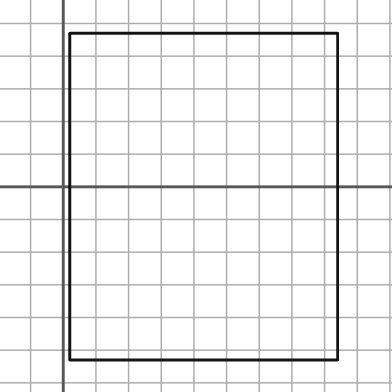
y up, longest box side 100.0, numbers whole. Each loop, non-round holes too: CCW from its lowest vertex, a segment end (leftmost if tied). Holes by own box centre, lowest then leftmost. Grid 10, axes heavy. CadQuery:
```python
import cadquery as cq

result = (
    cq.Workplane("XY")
    .moveTo(2.0, -53.0)
    .lineTo(84.0, -53.0)
    .lineTo(84.0, 47.0)
    .lineTo(2.0, 47.0)
    .close()
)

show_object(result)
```